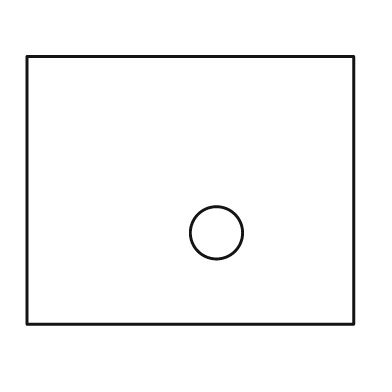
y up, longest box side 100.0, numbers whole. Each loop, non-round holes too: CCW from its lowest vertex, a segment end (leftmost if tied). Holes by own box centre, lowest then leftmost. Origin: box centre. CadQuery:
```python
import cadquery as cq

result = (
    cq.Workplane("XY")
    .moveTo(-50.0, -41.0)
    .lineTo(50.0, -41.0)
    .lineTo(50.0, 41.0)
    .lineTo(-50.0, 41.0)
    .close()
    .moveTo(8.0, -13.0)
    .circle(8.0)
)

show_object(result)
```